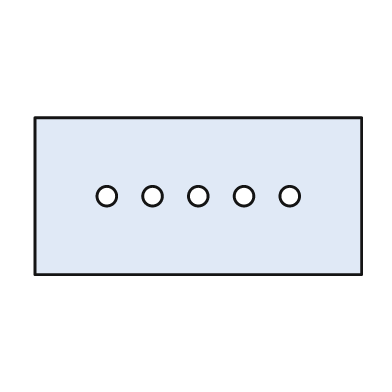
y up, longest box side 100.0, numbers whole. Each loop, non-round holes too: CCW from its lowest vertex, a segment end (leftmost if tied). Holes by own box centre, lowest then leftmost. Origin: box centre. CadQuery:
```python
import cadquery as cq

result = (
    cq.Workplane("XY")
    .moveTo(-50.0, -24.0)
    .lineTo(50.0, -24.0)
    .lineTo(50.0, 24.0)
    .lineTo(-50.0, 24.0)
    .close()
    .moveTo(-28.0, 0.0)
    .circle(3.0)
    .moveTo(-14.0, 0.0)
    .circle(3.0)
    .moveTo(0.0, 0.0)
    .circle(3.0)
    .moveTo(14.0, 0.0)
    .circle(3.0)
    .moveTo(28.0, 0.0)
    .circle(3.0)
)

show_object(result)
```